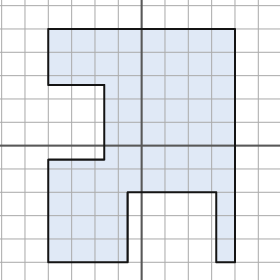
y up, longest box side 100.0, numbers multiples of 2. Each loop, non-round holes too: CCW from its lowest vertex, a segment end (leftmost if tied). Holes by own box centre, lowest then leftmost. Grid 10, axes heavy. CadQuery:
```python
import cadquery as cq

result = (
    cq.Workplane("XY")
    .moveTo(-40.0, -50.0)
    .lineTo(-6.0, -50.0)
    .lineTo(-6.0, -20.0)
    .lineTo(32.0, -20.0)
    .lineTo(32.0, -50.0)
    .lineTo(40.0, -50.0)
    .lineTo(40.0, 50.0)
    .lineTo(-40.0, 50.0)
    .lineTo(-40.0, 26.0)
    .lineTo(-16.0, 26.0)
    .lineTo(-16.0, -6.0)
    .lineTo(-40.0, -6.0)
    .close()
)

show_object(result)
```